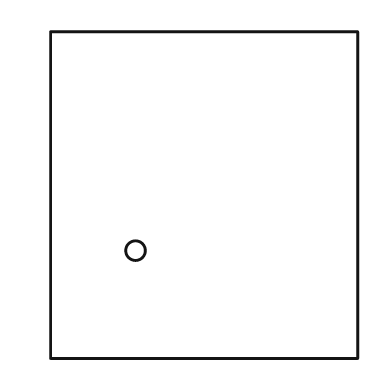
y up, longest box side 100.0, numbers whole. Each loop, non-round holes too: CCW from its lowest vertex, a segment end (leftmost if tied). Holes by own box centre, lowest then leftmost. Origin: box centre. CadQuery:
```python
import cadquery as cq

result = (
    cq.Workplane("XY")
    .moveTo(-47.0, -50.0)
    .lineTo(47.0, -50.0)
    .lineTo(47.0, 50.0)
    .lineTo(-47.0, 50.0)
    .close()
    .moveTo(-21.0, -17.0)
    .circle(3.0)
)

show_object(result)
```